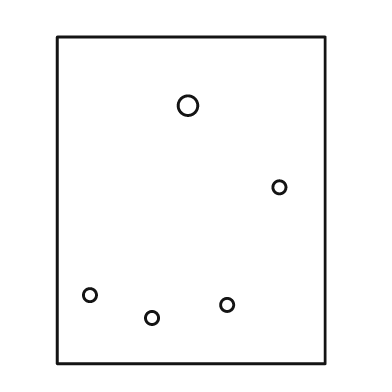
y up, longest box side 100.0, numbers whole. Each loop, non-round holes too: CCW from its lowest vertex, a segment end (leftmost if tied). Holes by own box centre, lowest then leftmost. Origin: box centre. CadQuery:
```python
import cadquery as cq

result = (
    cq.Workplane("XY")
    .moveTo(-41.0, -50.0)
    .lineTo(41.0, -50.0)
    .lineTo(41.0, 50.0)
    .lineTo(-41.0, 50.0)
    .close()
    .moveTo(-12.0, -36.0)
    .circle(2.0)
    .moveTo(11.0, -32.0)
    .circle(2.0)
    .moveTo(-31.0, -29.0)
    .circle(2.0)
    .moveTo(27.0, 4.0)
    .circle(2.0)
    .moveTo(-1.0, 29.0)
    .circle(3.0)
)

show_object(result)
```